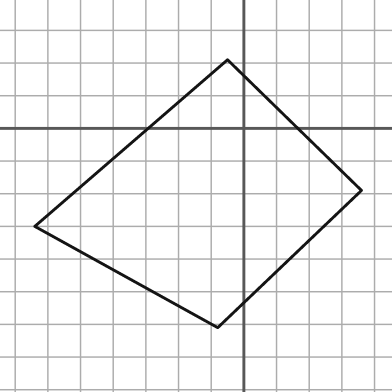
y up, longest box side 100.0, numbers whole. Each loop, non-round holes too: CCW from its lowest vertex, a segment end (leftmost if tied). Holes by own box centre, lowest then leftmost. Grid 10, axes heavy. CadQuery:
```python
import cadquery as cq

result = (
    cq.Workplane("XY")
    .moveTo(-8.0, -61.0)
    .lineTo(36.0, -19.0)
    .lineTo(-5.0, 21.0)
    .lineTo(-64.0, -30.0)
    .close()
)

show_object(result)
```